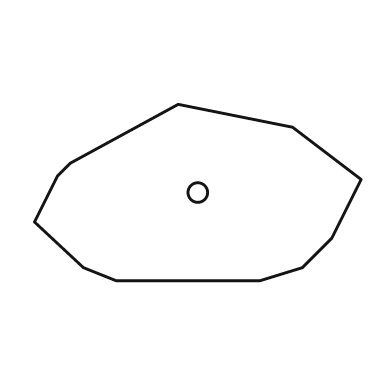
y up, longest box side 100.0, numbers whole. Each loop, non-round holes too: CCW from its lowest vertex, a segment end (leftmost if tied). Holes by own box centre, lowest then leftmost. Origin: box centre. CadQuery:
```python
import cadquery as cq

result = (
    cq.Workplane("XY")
    .moveTo(-25.0, -27.0)
    .lineTo(19.0, -27.0)
    .lineTo(32.0, -23.0)
    .lineTo(41.0, -14.0)
    .lineTo(50.0, 4.0)
    .lineTo(29.0, 20.0)
    .lineTo(-6.0, 27.0)
    .lineTo(-39.0, 9.0)
    .lineTo(-43.0, 5.0)
    .lineTo(-50.0, -9.0)
    .lineTo(-35.0, -23.0)
    .close()
    .moveTo(0.0, 0.0)
    .circle(3.0)
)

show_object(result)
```